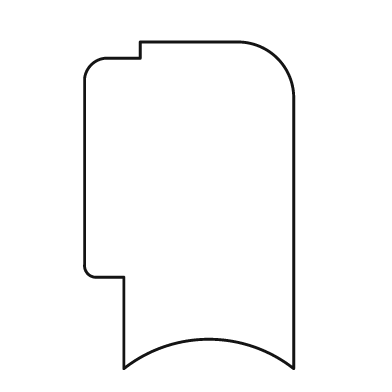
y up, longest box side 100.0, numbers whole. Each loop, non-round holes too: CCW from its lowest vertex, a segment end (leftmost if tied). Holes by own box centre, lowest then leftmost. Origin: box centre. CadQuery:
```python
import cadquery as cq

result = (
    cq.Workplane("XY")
    .moveTo(-20.0, -50.0)
    .threePointArc((6.0, -41.0), (32.0, -50.0))
    .lineTo(32.0, 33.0)
    .threePointArc((27.0, 45.0), (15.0, 50.0))
    .lineTo(-15.0, 50.0)
    .lineTo(-15.0, 45.0)
    .lineTo(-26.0, 45.0)
    .threePointArc((-30.0, 43.0), (-32.0, 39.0))
    .lineTo(-32.0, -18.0)
    .threePointArc((-31.0, -21.0), (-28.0, -22.0))
    .lineTo(-20.0, -22.0)
    .close()
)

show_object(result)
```